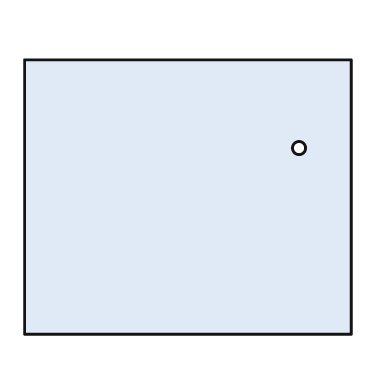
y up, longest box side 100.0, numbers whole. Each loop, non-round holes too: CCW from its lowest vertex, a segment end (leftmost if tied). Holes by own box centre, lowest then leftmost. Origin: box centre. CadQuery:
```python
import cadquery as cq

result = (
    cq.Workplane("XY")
    .moveTo(-50.0, -42.0)
    .lineTo(50.0, -42.0)
    .lineTo(50.0, 42.0)
    .lineTo(-50.0, 42.0)
    .close()
    .moveTo(34.0, 15.0)
    .circle(2.0)
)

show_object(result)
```